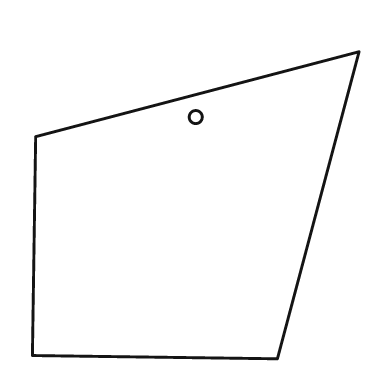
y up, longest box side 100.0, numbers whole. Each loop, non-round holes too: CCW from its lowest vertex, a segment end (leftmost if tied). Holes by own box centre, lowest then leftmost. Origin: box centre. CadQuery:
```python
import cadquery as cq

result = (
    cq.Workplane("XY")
    .moveTo(25.0, -47.0)
    .lineTo(50.0, 47.0)
    .lineTo(-49.0, 21.0)
    .lineTo(-50.0, -46.0)
    .close()
    .moveTo(0.0, 27.0)
    .circle(2.0)
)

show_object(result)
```